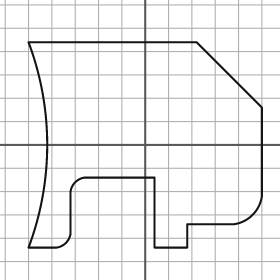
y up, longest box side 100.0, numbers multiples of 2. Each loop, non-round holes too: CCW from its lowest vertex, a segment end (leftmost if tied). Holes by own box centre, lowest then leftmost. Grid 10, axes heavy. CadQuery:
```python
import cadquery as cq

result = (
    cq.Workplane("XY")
    .moveTo(-50.0, -44.0)
    .lineTo(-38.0, -44.0)
    .threePointArc((-34.0, -42.0), (-32.0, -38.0))
    .lineTo(-32.0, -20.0)
    .threePointArc((-30.0, -16.0), (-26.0, -14.0))
    .lineTo(4.0, -14.0)
    .lineTo(4.0, -44.0)
    .lineTo(18.0, -44.0)
    .lineTo(18.0, -34.0)
    .lineTo(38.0, -34.0)
    .threePointArc((46.0, -30.0), (50.0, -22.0))
    .lineTo(50.0, 16.0)
    .lineTo(22.0, 44.0)
    .lineTo(-50.0, 44.0)
    .threePointArc((-42.0, 0.0), (-50.0, -44.0))
    .close()
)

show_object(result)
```